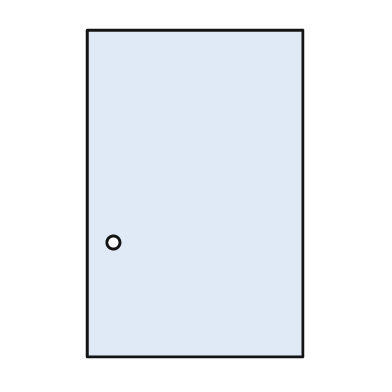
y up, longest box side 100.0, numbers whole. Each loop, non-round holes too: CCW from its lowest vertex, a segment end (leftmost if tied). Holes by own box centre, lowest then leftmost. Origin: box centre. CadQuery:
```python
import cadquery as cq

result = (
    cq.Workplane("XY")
    .moveTo(-33.0, -50.0)
    .lineTo(33.0, -50.0)
    .lineTo(33.0, 50.0)
    .lineTo(-33.0, 50.0)
    .close()
    .moveTo(-25.0, -15.0)
    .circle(2.0)
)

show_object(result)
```